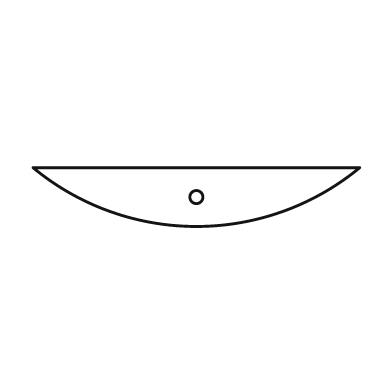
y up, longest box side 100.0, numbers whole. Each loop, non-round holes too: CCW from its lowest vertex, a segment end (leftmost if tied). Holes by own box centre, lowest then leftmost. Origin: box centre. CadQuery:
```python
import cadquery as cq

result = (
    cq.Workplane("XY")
    .moveTo(-50.0, 9.0)
    .threePointArc((0.0, -9.0), (50.0, 9.0))
    .close()
    .moveTo(0.0, 0.0)
    .circle(2.0)
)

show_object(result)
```